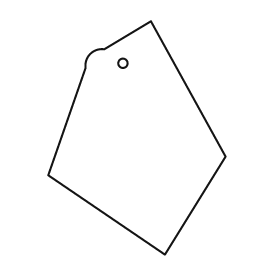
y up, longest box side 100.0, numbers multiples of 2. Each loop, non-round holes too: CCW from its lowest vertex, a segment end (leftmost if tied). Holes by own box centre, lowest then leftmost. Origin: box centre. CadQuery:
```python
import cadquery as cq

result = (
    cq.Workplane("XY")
    .moveTo(12.0, -50.0)
    .lineTo(38.0, -8.0)
    .lineTo(6.0, 50.0)
    .lineTo(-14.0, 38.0)
    .threePointArc((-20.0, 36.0), (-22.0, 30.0))
    .lineTo(-38.0, -16.0)
    .close()
    .moveTo(-6.0, 32.0)
    .circle(2.0)
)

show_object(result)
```